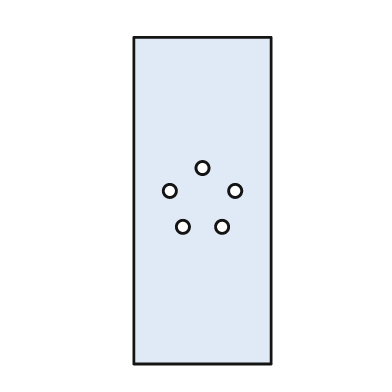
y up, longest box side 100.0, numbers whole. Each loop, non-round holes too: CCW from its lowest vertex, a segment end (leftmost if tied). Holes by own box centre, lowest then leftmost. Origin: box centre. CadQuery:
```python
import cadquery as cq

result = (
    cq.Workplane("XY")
    .moveTo(-21.0, -50.0)
    .lineTo(21.0, -50.0)
    .lineTo(21.0, 50.0)
    .lineTo(-21.0, 50.0)
    .close()
    .moveTo(-6.0, -8.0)
    .circle(2.0)
    .moveTo(6.0, -8.0)
    .circle(2.0)
    .moveTo(-10.0, 3.0)
    .circle(2.0)
    .moveTo(10.0, 3.0)
    .circle(2.0)
    .moveTo(0.0, 10.0)
    .circle(2.0)
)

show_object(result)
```